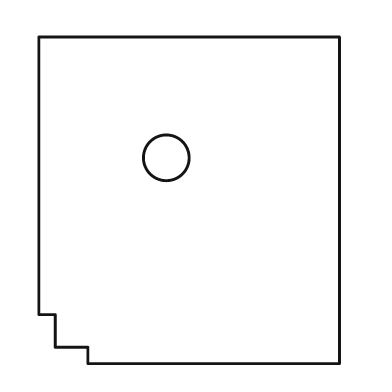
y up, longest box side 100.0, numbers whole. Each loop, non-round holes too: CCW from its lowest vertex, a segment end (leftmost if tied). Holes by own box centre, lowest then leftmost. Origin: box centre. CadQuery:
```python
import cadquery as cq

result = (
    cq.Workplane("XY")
    .moveTo(-31.0, -50.0)
    .lineTo(46.0, -50.0)
    .lineTo(46.0, 50.0)
    .lineTo(-46.0, 50.0)
    .lineTo(-46.0, -35.0)
    .lineTo(-41.0, -35.0)
    .lineTo(-41.0, -45.0)
    .lineTo(-31.0, -45.0)
    .close()
    .moveTo(-7.0, 13.0)
    .circle(7.0)
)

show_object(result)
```